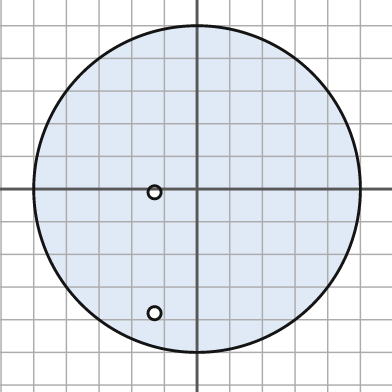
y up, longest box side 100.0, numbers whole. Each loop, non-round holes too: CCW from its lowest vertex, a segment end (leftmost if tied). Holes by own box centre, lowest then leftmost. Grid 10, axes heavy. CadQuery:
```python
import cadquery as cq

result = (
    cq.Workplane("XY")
    .moveTo(0.0, 0.0)
    .circle(50.0)
    .moveTo(-13.0, -38.0)
    .circle(2.0)
    .moveTo(-13.0, -1.0)
    .circle(2.0)
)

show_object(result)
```